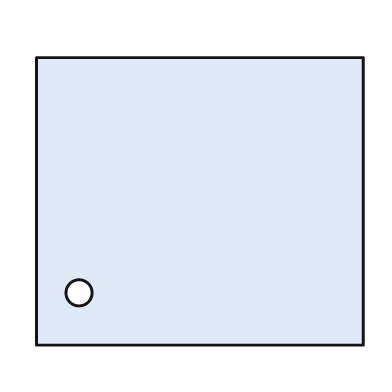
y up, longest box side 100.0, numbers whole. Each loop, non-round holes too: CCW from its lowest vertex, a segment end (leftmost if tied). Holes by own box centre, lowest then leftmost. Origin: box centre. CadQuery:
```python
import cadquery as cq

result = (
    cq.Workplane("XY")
    .moveTo(-50.0, -44.0)
    .lineTo(50.0, -44.0)
    .lineTo(50.0, 44.0)
    .lineTo(-50.0, 44.0)
    .close()
    .moveTo(-37.0, -28.0)
    .circle(4.0)
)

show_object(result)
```